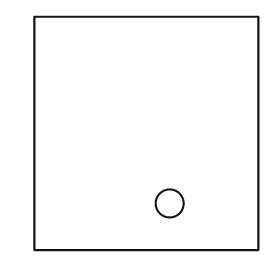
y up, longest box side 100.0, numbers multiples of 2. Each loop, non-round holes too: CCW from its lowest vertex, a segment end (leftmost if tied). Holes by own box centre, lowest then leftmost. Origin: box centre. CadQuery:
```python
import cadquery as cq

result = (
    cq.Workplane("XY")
    .moveTo(-48.0, -50.0)
    .lineTo(48.0, -50.0)
    .lineTo(48.0, 50.0)
    .lineTo(-48.0, 50.0)
    .close()
    .moveTo(10.0, -30.0)
    .circle(6.0)
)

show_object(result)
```